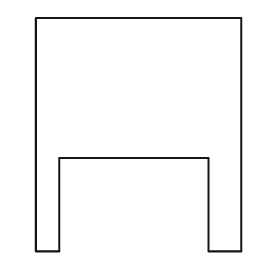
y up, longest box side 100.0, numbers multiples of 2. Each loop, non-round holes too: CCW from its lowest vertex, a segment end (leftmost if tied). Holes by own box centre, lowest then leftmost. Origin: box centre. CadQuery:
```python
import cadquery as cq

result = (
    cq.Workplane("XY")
    .moveTo(-44.0, -50.0)
    .lineTo(-34.0, -50.0)
    .lineTo(-34.0, -10.0)
    .lineTo(30.0, -10.0)
    .lineTo(30.0, -50.0)
    .lineTo(44.0, -50.0)
    .lineTo(44.0, 50.0)
    .lineTo(-44.0, 50.0)
    .close()
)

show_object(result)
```